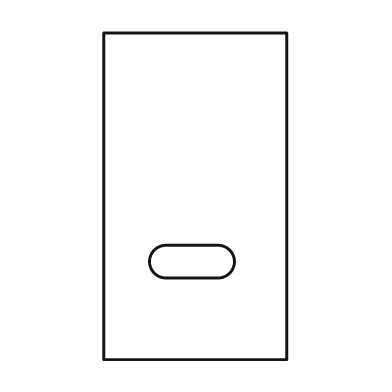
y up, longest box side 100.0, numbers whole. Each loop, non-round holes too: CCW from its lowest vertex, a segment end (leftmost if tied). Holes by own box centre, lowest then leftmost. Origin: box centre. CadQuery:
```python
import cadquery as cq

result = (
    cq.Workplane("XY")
    .moveTo(-28.0, -50.0)
    .lineTo(28.0, -50.0)
    .lineTo(28.0, 50.0)
    .lineTo(-28.0, 50.0)
    .close()
    .moveTo(-9.0, -25.0)
    .lineTo(7.0, -25.0)
    .threePointArc((12.0, -20.0), (7.0, -15.0))
    .lineTo(-9.0, -15.0)
    .threePointArc((-14.0, -20.0), (-9.0, -25.0))
    .close()
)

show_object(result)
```